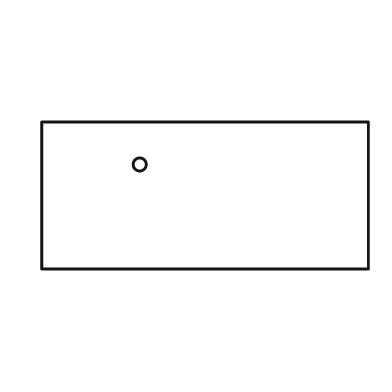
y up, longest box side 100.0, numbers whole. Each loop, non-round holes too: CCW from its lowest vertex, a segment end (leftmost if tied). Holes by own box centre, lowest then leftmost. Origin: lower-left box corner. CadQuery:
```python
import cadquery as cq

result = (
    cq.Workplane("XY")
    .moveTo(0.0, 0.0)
    .lineTo(100.0, 0.0)
    .lineTo(100.0, 45.0)
    .lineTo(0.0, 45.0)
    .close()
    .moveTo(30.0, 32.0)
    .circle(2.0)
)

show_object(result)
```